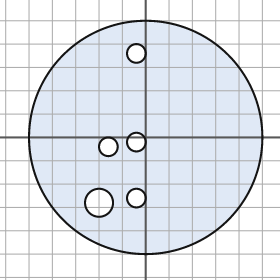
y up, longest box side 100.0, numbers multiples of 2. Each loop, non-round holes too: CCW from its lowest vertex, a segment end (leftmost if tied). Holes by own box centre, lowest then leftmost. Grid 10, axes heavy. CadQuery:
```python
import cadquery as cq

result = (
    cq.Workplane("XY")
    .moveTo(0.0, 0.0)
    .circle(50.0)
    .moveTo(-20.0, -28.0)
    .circle(6.0)
    .moveTo(-4.0, -26.0)
    .circle(4.0)
    .moveTo(-16.0, -4.0)
    .circle(4.0)
    .moveTo(-4.0, -2.0)
    .circle(4.0)
    .moveTo(-4.0, 36.0)
    .circle(4.0)
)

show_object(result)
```